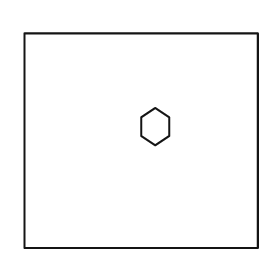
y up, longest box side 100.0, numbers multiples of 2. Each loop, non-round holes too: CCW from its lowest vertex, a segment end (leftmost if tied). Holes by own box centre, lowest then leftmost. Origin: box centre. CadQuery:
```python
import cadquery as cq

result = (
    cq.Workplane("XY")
    .moveTo(-50.0, -46.0)
    .lineTo(50.0, -46.0)
    .lineTo(50.0, 46.0)
    .lineTo(-50.0, 46.0)
    .close()
    .moveTo(6.0, -2.0)
    .lineTo(12.0, 2.0)
    .lineTo(12.0, 10.0)
    .lineTo(6.0, 14.0)
    .lineTo(0.0, 10.0)
    .lineTo(0.0, 2.0)
    .close()
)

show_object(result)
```